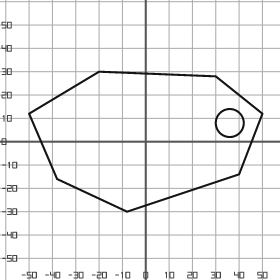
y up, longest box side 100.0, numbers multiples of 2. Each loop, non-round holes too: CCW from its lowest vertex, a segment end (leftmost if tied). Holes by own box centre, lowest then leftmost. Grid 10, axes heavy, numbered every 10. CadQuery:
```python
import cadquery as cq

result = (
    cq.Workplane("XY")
    .moveTo(-8.0, -30.0)
    .lineTo(40.0, -14.0)
    .lineTo(50.0, 12.0)
    .lineTo(30.0, 28.0)
    .lineTo(-20.0, 30.0)
    .lineTo(-50.0, 12.0)
    .lineTo(-38.0, -16.0)
    .close()
    .moveTo(36.0, 8.0)
    .circle(6.0)
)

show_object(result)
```